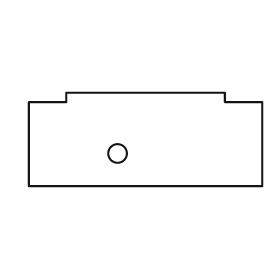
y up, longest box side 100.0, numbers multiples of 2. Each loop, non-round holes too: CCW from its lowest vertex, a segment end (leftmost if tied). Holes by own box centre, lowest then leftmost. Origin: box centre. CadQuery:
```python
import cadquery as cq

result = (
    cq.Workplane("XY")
    .moveTo(-50.0, -20.0)
    .lineTo(50.0, -20.0)
    .lineTo(50.0, 16.0)
    .lineTo(34.0, 16.0)
    .lineTo(34.0, 20.0)
    .lineTo(-34.0, 20.0)
    .lineTo(-34.0, 16.0)
    .lineTo(-50.0, 16.0)
    .close()
    .moveTo(-12.0, -6.0)
    .circle(4.0)
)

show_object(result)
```